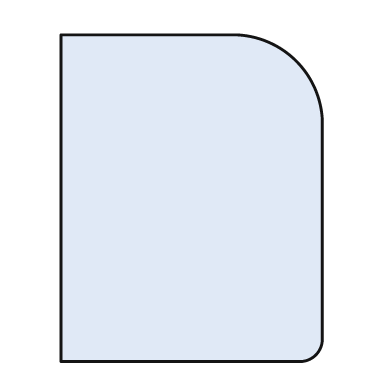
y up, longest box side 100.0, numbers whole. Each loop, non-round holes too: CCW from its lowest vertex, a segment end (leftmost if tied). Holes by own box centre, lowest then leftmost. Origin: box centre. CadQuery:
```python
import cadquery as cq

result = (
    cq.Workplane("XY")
    .moveTo(-40.0, -50.0)
    .lineTo(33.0, -50.0)
    .threePointArc((38.0, -48.0), (40.0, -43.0))
    .lineTo(40.0, 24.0)
    .threePointArc((32.0, 42.0), (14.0, 50.0))
    .lineTo(-40.0, 50.0)
    .close()
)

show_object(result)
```